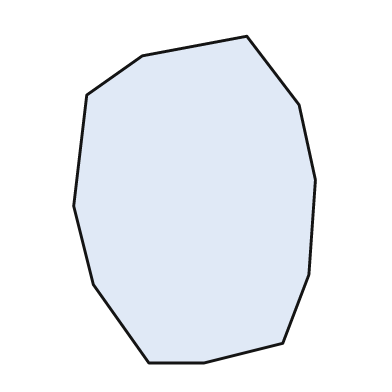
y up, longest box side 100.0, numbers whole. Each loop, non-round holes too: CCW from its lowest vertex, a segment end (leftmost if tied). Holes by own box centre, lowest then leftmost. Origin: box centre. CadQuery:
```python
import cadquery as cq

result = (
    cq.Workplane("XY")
    .moveTo(-14.0, -50.0)
    .lineTo(3.0, -50.0)
    .lineTo(27.0, -44.0)
    .lineTo(35.0, -23.0)
    .lineTo(37.0, 6.0)
    .lineTo(32.0, 29.0)
    .lineTo(16.0, 50.0)
    .lineTo(-16.0, 44.0)
    .lineTo(-33.0, 32.0)
    .lineTo(-37.0, -2.0)
    .lineTo(-31.0, -26.0)
    .close()
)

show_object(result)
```